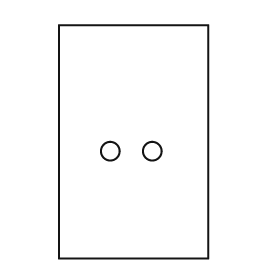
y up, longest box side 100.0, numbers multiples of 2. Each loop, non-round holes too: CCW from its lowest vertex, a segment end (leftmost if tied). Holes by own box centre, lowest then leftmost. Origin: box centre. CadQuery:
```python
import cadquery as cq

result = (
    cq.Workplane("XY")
    .moveTo(-32.0, -50.0)
    .lineTo(32.0, -50.0)
    .lineTo(32.0, 50.0)
    .lineTo(-32.0, 50.0)
    .close()
    .moveTo(-10.0, -4.0)
    .circle(4.0)
    .moveTo(8.0, -4.0)
    .circle(4.0)
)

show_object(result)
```